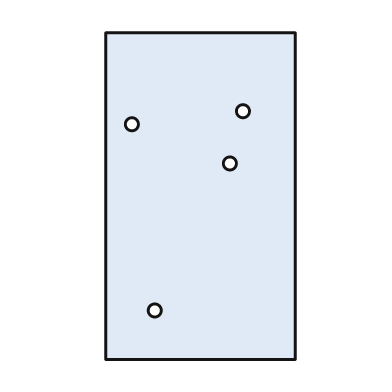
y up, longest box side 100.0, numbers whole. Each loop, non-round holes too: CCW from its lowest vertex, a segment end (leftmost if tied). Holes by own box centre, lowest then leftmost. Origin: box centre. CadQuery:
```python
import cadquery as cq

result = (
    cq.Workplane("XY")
    .moveTo(-29.0, -50.0)
    .lineTo(29.0, -50.0)
    .lineTo(29.0, 50.0)
    .lineTo(-29.0, 50.0)
    .close()
    .moveTo(-14.0, -35.0)
    .circle(2.0)
    .moveTo(9.0, 10.0)
    .circle(2.0)
    .moveTo(-21.0, 22.0)
    .circle(2.0)
    .moveTo(13.0, 26.0)
    .circle(2.0)
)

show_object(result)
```